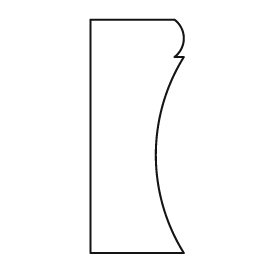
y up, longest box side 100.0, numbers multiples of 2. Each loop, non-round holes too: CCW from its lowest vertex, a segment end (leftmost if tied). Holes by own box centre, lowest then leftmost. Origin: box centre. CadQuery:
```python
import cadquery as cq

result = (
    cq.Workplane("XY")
    .moveTo(-20.0, -50.0)
    .lineTo(20.0, -50.0)
    .threePointArc((8.0, -8.0), (20.0, 34.0))
    .lineTo(16.0, 34.0)
    .threePointArc((20.0, 42.0), (16.0, 50.0))
    .lineTo(-20.0, 50.0)
    .close()
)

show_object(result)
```